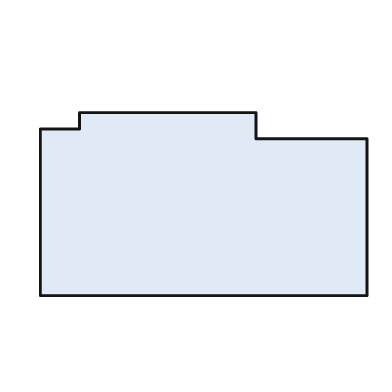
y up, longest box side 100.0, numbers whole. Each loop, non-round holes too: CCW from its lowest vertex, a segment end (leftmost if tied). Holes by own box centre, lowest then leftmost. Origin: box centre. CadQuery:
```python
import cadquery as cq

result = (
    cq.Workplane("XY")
    .moveTo(-50.0, -28.0)
    .lineTo(50.0, -28.0)
    .lineTo(50.0, 20.0)
    .lineTo(16.0, 20.0)
    .lineTo(16.0, 28.0)
    .lineTo(-38.0, 28.0)
    .lineTo(-38.0, 23.0)
    .lineTo(-50.0, 23.0)
    .close()
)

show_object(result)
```